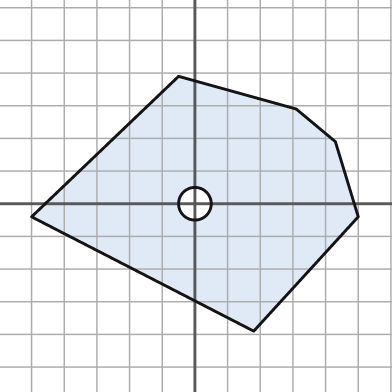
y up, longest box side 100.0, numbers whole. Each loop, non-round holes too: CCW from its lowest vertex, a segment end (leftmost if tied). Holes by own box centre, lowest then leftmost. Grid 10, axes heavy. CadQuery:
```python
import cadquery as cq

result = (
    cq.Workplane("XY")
    .moveTo(18.0, -39.0)
    .lineTo(50.0, -4.0)
    .lineTo(43.0, 19.0)
    .lineTo(31.0, 29.0)
    .lineTo(-5.0, 39.0)
    .lineTo(-50.0, -4.0)
    .close()
    .moveTo(0.0, 0.0)
    .circle(5.0)
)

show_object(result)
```